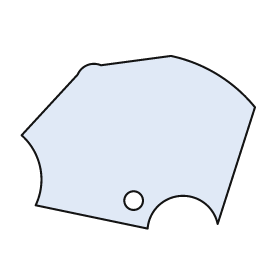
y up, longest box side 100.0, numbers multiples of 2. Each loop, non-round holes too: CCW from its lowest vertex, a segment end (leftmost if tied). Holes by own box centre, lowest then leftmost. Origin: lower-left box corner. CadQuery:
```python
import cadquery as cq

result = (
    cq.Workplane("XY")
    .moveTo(54.0, 0.0)
    .threePointArc((68.0, 14.0), (84.0, 2.0))
    .lineTo(100.0, 52.0)
    .threePointArc((84.0, 66.0), (64.0, 74.0))
    .lineTo(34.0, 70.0)
    .threePointArc((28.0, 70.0), (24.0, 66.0))
    .lineTo(0.0, 40.0)
    .threePointArc((8.0, 26.0), (6.0, 10.0))
    .close()
    .moveTo(48.0, 12.0)
    .circle(4.0)
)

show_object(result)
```